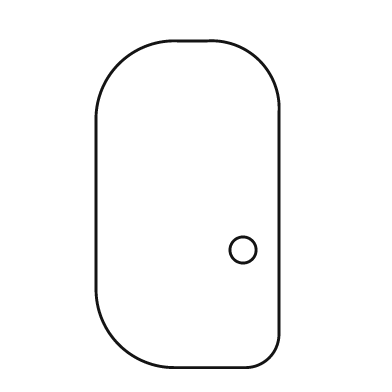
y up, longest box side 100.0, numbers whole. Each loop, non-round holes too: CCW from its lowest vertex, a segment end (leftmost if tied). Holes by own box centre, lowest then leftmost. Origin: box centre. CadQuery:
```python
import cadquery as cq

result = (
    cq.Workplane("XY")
    .moveTo(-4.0, -50.0)
    .lineTo(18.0, -50.0)
    .threePointArc((25.0, -47.0), (28.0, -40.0))
    .lineTo(28.0, 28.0)
    .threePointArc((22.0, 44.0), (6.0, 50.0))
    .lineTo(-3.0, 50.0)
    .threePointArc((-21.0, 43.0), (-28.0, 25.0))
    .lineTo(-28.0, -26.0)
    .threePointArc((-21.0, -43.0), (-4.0, -50.0))
    .close()
    .moveTo(17.0, -14.0)
    .circle(4.0)
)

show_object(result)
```